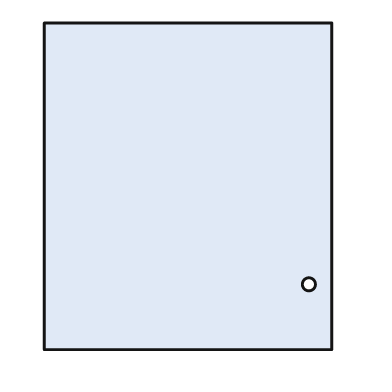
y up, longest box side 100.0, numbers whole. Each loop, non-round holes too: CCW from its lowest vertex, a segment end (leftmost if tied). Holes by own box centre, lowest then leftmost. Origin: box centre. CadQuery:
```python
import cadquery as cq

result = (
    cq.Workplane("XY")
    .moveTo(-44.0, -50.0)
    .lineTo(44.0, -50.0)
    .lineTo(44.0, 50.0)
    .lineTo(-44.0, 50.0)
    .close()
    .moveTo(37.0, -30.0)
    .circle(2.0)
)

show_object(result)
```